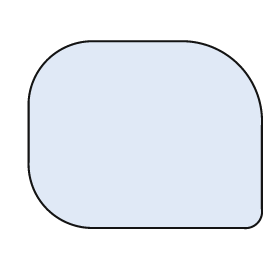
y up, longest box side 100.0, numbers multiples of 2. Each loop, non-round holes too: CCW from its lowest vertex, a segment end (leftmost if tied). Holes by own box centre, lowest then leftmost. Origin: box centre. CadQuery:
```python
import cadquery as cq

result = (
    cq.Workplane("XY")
    .moveTo(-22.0, -40.0)
    .lineTo(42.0, -40.0)
    .threePointArc((48.0, -38.0), (50.0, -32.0))
    .lineTo(50.0, 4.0)
    .threePointArc((40.0, 30.0), (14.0, 40.0))
    .lineTo(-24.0, 40.0)
    .threePointArc((-42.0, 32.0), (-50.0, 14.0))
    .lineTo(-50.0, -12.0)
    .threePointArc((-42.0, -32.0), (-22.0, -40.0))
    .close()
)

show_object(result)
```